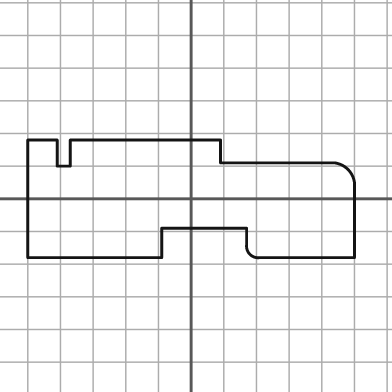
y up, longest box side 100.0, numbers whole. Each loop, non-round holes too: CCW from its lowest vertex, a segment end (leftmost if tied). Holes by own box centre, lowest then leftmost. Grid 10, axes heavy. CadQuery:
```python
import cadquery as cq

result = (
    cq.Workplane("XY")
    .moveTo(-50.0, -18.0)
    .lineTo(-9.0, -18.0)
    .lineTo(-9.0, -9.0)
    .lineTo(17.0, -9.0)
    .lineTo(17.0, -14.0)
    .threePointArc((18.0, -17.0), (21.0, -18.0))
    .lineTo(50.0, -18.0)
    .lineTo(50.0, 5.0)
    .threePointArc((48.0, 9.0), (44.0, 11.0))
    .lineTo(9.0, 11.0)
    .lineTo(9.0, 18.0)
    .lineTo(-37.0, 18.0)
    .lineTo(-37.0, 10.0)
    .lineTo(-41.0, 10.0)
    .lineTo(-41.0, 18.0)
    .lineTo(-50.0, 18.0)
    .close()
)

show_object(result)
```